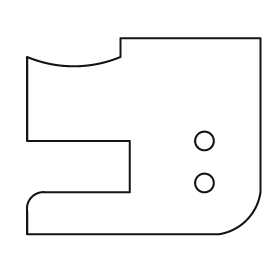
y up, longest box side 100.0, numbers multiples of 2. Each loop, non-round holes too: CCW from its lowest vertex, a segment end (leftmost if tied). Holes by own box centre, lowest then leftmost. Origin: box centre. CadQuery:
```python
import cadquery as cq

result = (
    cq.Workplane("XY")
    .moveTo(-50.0, -42.0)
    .lineTo(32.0, -42.0)
    .threePointArc((44.0, -36.0), (50.0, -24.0))
    .lineTo(50.0, 42.0)
    .lineTo(-10.0, 42.0)
    .lineTo(-10.0, 34.0)
    .threePointArc((-30.0, 30.0), (-50.0, 34.0))
    .lineTo(-50.0, -2.0)
    .lineTo(-6.0, -2.0)
    .lineTo(-6.0, -24.0)
    .lineTo(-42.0, -24.0)
    .threePointArc((-48.0, -26.0), (-50.0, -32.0))
    .close()
    .moveTo(26.0, -20.0)
    .circle(4.0)
    .moveTo(26.0, -2.0)
    .circle(4.0)
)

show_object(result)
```